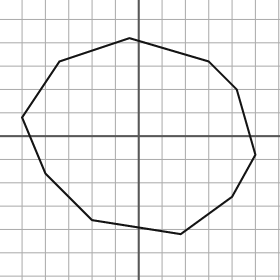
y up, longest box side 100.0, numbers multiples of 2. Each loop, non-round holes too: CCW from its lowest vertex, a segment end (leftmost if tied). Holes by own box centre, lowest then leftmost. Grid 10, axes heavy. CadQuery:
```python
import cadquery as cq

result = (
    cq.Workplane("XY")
    .moveTo(18.0, -42.0)
    .lineTo(40.0, -26.0)
    .lineTo(50.0, -8.0)
    .lineTo(42.0, 20.0)
    .lineTo(30.0, 32.0)
    .lineTo(-4.0, 42.0)
    .lineTo(-34.0, 32.0)
    .lineTo(-50.0, 8.0)
    .lineTo(-40.0, -16.0)
    .lineTo(-20.0, -36.0)
    .close()
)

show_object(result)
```